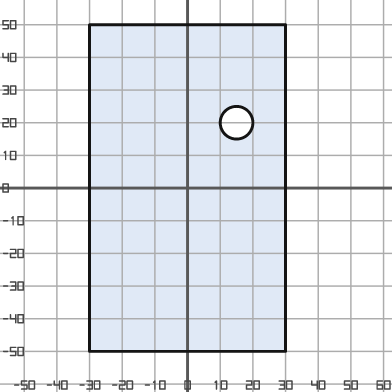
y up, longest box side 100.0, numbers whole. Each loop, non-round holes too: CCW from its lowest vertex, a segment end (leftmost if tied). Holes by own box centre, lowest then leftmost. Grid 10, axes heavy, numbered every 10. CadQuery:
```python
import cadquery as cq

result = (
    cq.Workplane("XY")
    .moveTo(-30.0, -50.0)
    .lineTo(30.0, -50.0)
    .lineTo(30.0, 50.0)
    .lineTo(-30.0, 50.0)
    .close()
    .moveTo(15.0, 20.0)
    .circle(5.0)
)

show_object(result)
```